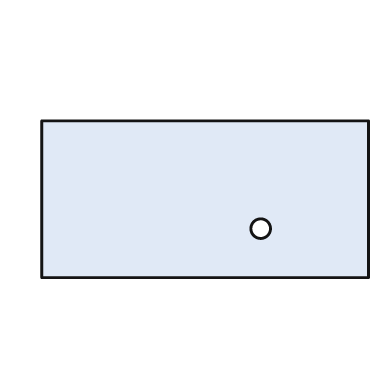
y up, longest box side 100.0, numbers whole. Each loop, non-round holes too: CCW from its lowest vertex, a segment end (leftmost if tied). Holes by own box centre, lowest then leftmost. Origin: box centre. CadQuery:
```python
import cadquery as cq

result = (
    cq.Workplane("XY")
    .moveTo(-50.0, -24.0)
    .lineTo(50.0, -24.0)
    .lineTo(50.0, 24.0)
    .lineTo(-50.0, 24.0)
    .close()
    .moveTo(17.0, -9.0)
    .circle(3.0)
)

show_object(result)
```